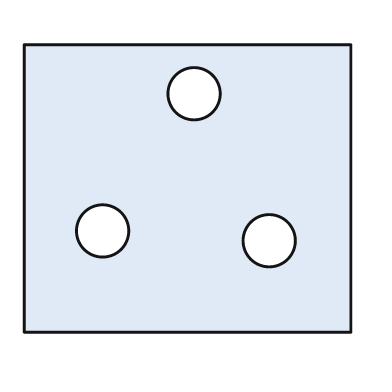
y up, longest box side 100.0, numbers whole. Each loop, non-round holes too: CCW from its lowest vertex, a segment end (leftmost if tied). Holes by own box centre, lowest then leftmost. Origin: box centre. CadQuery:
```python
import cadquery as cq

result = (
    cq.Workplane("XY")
    .moveTo(-50.0, -44.0)
    .lineTo(50.0, -44.0)
    .lineTo(50.0, 44.0)
    .lineTo(-50.0, 44.0)
    .close()
    .moveTo(25.0, -16.0)
    .circle(8.0)
    .moveTo(-26.0, -13.0)
    .circle(8.0)
    .moveTo(2.0, 29.0)
    .circle(8.0)
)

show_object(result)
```